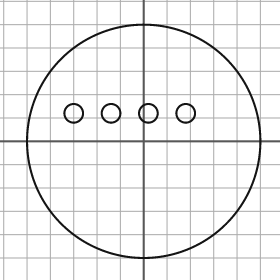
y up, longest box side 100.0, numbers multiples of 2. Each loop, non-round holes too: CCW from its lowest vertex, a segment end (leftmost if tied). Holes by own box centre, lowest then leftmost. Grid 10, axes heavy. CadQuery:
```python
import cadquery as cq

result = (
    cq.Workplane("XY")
    .moveTo(0.0, 0.0)
    .circle(50.0)
    .moveTo(-30.0, 12.0)
    .circle(4.0)
    .moveTo(-14.0, 12.0)
    .circle(4.0)
    .moveTo(2.0, 12.0)
    .circle(4.0)
    .moveTo(18.0, 12.0)
    .circle(4.0)
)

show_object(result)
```